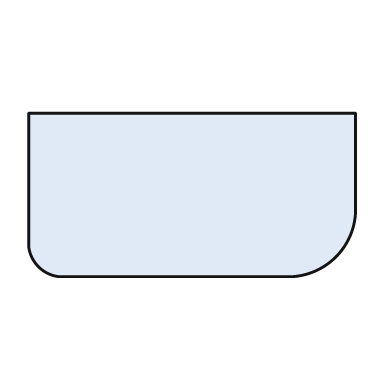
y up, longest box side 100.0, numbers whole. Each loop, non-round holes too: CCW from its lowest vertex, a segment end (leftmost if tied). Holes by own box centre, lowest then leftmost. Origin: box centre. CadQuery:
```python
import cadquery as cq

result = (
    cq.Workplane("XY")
    .moveTo(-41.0, -25.0)
    .lineTo(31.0, -25.0)
    .threePointArc((44.0, -19.0), (50.0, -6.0))
    .lineTo(50.0, 25.0)
    .lineTo(-50.0, 25.0)
    .lineTo(-50.0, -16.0)
    .threePointArc((-47.0, -22.0), (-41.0, -25.0))
    .close()
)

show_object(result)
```